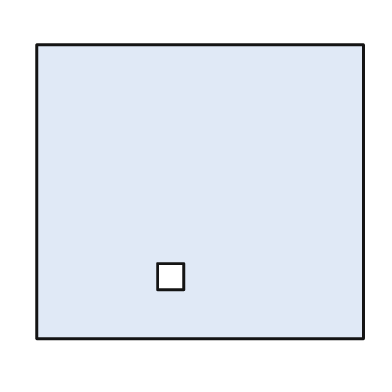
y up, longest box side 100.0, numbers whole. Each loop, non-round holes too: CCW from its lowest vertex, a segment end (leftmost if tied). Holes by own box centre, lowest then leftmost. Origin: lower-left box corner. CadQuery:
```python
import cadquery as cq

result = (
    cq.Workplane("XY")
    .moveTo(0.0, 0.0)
    .lineTo(100.0, 0.0)
    .lineTo(100.0, 90.0)
    .lineTo(0.0, 90.0)
    .close()
    .moveTo(37.0, 15.0)
    .lineTo(45.0, 15.0)
    .lineTo(45.0, 23.0)
    .lineTo(37.0, 23.0)
    .close()
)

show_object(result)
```